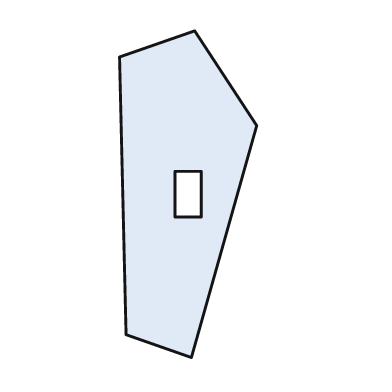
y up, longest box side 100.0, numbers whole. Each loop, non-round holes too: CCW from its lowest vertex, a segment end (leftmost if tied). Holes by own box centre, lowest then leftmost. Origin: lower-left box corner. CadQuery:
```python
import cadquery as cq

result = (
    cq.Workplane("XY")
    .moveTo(22.0, 0.0)
    .lineTo(42.0, 71.0)
    .lineTo(23.0, 100.0)
    .lineTo(0.0, 92.0)
    .lineTo(2.0, 7.0)
    .close()
    .moveTo(17.0, 43.0)
    .lineTo(25.0, 43.0)
    .lineTo(25.0, 57.0)
    .lineTo(17.0, 57.0)
    .close()
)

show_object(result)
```